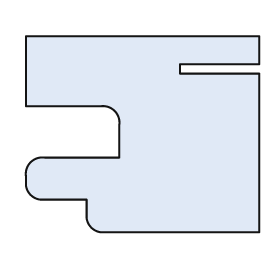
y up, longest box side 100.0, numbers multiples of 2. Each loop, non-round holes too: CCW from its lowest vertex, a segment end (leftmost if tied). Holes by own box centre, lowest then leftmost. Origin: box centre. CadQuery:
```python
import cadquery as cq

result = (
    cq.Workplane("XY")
    .moveTo(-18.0, -42.0)
    .lineTo(50.0, -42.0)
    .lineTo(50.0, 26.0)
    .lineTo(16.0, 26.0)
    .lineTo(16.0, 30.0)
    .lineTo(50.0, 30.0)
    .lineTo(50.0, 42.0)
    .lineTo(-50.0, 42.0)
    .lineTo(-50.0, 12.0)
    .lineTo(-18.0, 12.0)
    .threePointArc((-12.0, 10.0), (-10.0, 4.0))
    .lineTo(-10.0, -10.0)
    .lineTo(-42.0, -10.0)
    .threePointArc((-48.0, -12.0), (-50.0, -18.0))
    .lineTo(-50.0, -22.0)
    .threePointArc((-48.0, -26.0), (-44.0, -28.0))
    .lineTo(-24.0, -28.0)
    .lineTo(-24.0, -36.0)
    .threePointArc((-22.0, -40.0), (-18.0, -42.0))
    .close()
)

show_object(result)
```